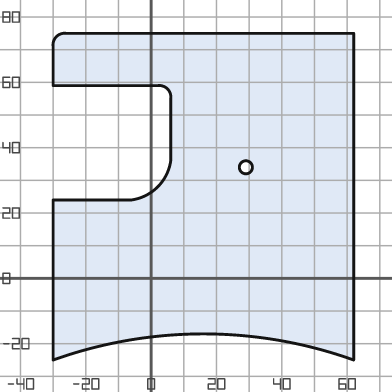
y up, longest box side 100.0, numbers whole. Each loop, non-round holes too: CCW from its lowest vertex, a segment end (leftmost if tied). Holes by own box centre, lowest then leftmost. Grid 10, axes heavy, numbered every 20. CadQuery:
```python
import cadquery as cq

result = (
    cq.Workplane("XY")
    .moveTo(-30.0, -25.0)
    .threePointArc((16.0, -17.0), (62.0, -25.0))
    .lineTo(62.0, 75.0)
    .lineTo(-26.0, 75.0)
    .threePointArc((-29.0, 74.0), (-30.0, 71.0))
    .lineTo(-30.0, 59.0)
    .lineTo(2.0, 59.0)
    .threePointArc((5.0, 58.0), (6.0, 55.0))
    .lineTo(6.0, 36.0)
    .threePointArc((2.0, 28.0), (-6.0, 24.0))
    .lineTo(-30.0, 24.0)
    .close()
    .moveTo(29.0, 34.0)
    .circle(2.0)
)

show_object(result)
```